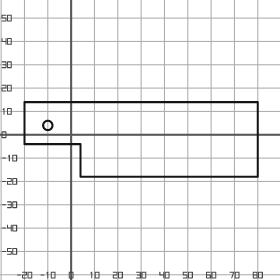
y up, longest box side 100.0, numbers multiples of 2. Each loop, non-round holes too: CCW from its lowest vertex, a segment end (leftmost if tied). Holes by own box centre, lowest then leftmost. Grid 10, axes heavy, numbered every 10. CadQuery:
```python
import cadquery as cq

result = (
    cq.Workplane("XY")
    .moveTo(4.0, -18.0)
    .lineTo(80.0, -18.0)
    .lineTo(80.0, 14.0)
    .lineTo(-20.0, 14.0)
    .lineTo(-20.0, -4.0)
    .lineTo(4.0, -4.0)
    .close()
    .moveTo(-10.0, 4.0)
    .circle(2.0)
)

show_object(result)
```